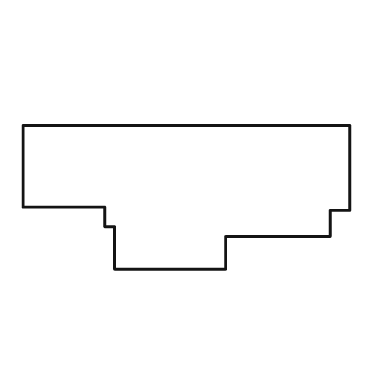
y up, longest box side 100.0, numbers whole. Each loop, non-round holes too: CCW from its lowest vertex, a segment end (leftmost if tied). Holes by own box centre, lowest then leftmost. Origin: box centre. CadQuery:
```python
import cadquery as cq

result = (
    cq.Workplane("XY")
    .moveTo(-22.0, -22.0)
    .lineTo(12.0, -22.0)
    .lineTo(12.0, -12.0)
    .lineTo(44.0, -12.0)
    .lineTo(44.0, -4.0)
    .lineTo(50.0, -4.0)
    .lineTo(50.0, 22.0)
    .lineTo(-50.0, 22.0)
    .lineTo(-50.0, -3.0)
    .lineTo(-25.0, -3.0)
    .lineTo(-25.0, -9.0)
    .lineTo(-22.0, -9.0)
    .close()
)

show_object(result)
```